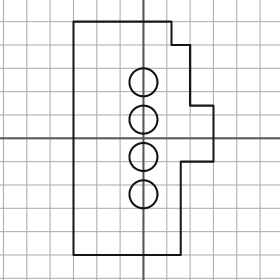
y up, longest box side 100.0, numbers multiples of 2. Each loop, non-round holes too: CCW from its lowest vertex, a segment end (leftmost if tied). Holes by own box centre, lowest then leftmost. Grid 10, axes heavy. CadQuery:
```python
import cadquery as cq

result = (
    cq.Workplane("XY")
    .moveTo(-30.0, -50.0)
    .lineTo(16.0, -50.0)
    .lineTo(16.0, -10.0)
    .lineTo(30.0, -10.0)
    .lineTo(30.0, 14.0)
    .lineTo(20.0, 14.0)
    .lineTo(20.0, 40.0)
    .lineTo(12.0, 40.0)
    .lineTo(12.0, 50.0)
    .lineTo(-30.0, 50.0)
    .close()
    .moveTo(0.0, -24.0)
    .circle(6.0)
    .moveTo(0.0, -8.0)
    .circle(6.0)
    .moveTo(0.0, 8.0)
    .circle(6.0)
    .moveTo(0.0, 24.0)
    .circle(6.0)
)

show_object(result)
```